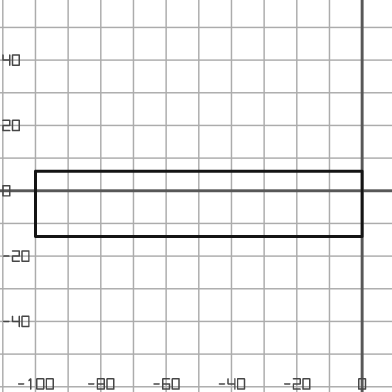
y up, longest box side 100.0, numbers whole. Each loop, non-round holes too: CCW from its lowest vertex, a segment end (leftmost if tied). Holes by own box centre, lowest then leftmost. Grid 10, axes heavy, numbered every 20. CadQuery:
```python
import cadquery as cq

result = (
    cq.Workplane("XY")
    .moveTo(-100.0, -14.0)
    .lineTo(0.0, -14.0)
    .lineTo(0.0, 6.0)
    .lineTo(-100.0, 6.0)
    .close()
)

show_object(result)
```